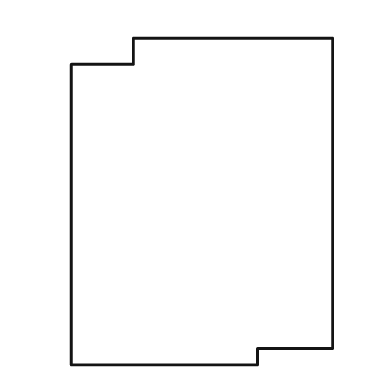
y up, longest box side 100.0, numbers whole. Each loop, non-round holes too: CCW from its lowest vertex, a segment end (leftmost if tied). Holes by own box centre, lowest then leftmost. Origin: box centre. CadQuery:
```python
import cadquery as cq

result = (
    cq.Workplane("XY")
    .moveTo(-40.0, -50.0)
    .lineTo(17.0, -50.0)
    .lineTo(17.0, -45.0)
    .lineTo(40.0, -45.0)
    .lineTo(40.0, 50.0)
    .lineTo(-21.0, 50.0)
    .lineTo(-21.0, 42.0)
    .lineTo(-40.0, 42.0)
    .close()
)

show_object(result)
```